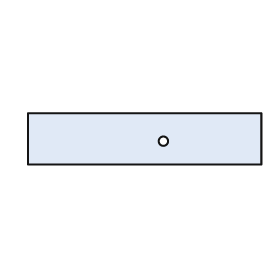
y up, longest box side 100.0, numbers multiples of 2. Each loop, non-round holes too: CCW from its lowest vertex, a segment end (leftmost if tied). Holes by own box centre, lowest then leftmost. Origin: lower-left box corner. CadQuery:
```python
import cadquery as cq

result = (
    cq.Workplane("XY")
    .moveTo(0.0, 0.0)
    .lineTo(100.0, 0.0)
    .lineTo(100.0, 22.0)
    .lineTo(0.0, 22.0)
    .close()
    .moveTo(58.0, 10.0)
    .circle(2.0)
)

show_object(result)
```